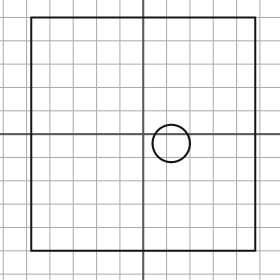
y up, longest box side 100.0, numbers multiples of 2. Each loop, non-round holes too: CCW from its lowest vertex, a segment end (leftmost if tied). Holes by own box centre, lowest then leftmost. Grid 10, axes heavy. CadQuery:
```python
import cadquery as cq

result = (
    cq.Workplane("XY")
    .moveTo(-48.0, -50.0)
    .lineTo(48.0, -50.0)
    .lineTo(48.0, 50.0)
    .lineTo(-48.0, 50.0)
    .close()
    .moveTo(12.0, -4.0)
    .circle(8.0)
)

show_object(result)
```